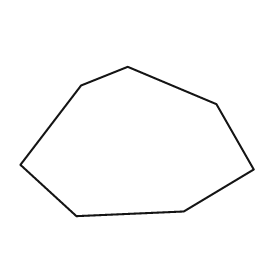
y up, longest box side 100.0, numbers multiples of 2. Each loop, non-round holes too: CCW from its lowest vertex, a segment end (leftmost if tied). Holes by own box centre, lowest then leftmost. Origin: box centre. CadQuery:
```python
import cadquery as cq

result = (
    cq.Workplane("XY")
    .moveTo(-26.0, -32.0)
    .lineTo(20.0, -30.0)
    .lineTo(50.0, -12.0)
    .lineTo(34.0, 16.0)
    .lineTo(-4.0, 32.0)
    .lineTo(-24.0, 24.0)
    .lineTo(-50.0, -10.0)
    .close()
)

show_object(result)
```